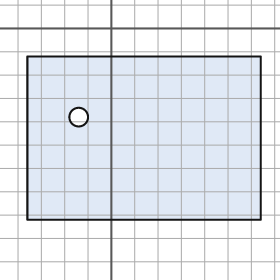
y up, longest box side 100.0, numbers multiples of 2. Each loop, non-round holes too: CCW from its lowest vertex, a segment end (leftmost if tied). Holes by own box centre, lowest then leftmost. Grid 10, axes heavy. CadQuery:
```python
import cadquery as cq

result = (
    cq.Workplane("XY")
    .moveTo(-36.0, -82.0)
    .lineTo(64.0, -82.0)
    .lineTo(64.0, -12.0)
    .lineTo(-36.0, -12.0)
    .close()
    .moveTo(-14.0, -38.0)
    .circle(4.0)
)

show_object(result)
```